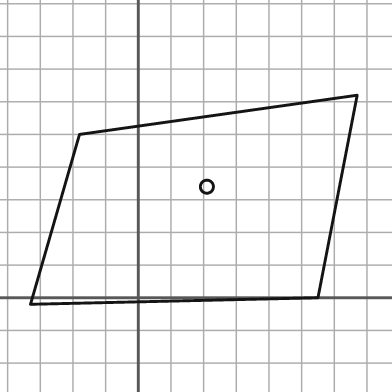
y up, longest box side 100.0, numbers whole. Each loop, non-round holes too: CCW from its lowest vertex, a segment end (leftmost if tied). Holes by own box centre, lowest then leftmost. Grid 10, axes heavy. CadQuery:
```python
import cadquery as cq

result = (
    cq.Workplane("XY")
    .moveTo(-33.0, -2.0)
    .lineTo(55.0, 0.0)
    .lineTo(67.0, 62.0)
    .lineTo(-18.0, 50.0)
    .close()
    .moveTo(21.0, 34.0)
    .circle(2.0)
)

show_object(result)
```